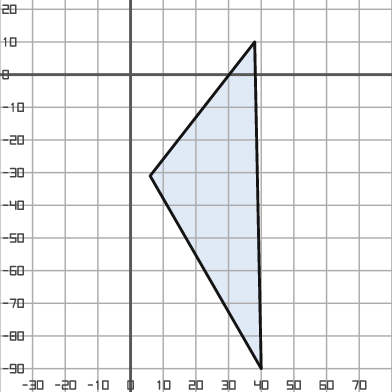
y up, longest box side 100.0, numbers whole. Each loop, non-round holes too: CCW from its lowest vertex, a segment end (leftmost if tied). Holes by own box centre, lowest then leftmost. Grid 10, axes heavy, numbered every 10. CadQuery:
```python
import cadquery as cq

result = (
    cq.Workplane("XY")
    .moveTo(40.0, -90.0)
    .lineTo(38.0, 10.0)
    .lineTo(6.0, -31.0)
    .close()
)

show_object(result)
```